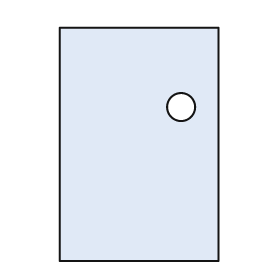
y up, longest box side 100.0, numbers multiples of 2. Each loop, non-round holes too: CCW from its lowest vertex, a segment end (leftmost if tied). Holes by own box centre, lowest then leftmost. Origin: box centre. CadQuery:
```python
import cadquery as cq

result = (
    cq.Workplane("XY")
    .moveTo(-34.0, -50.0)
    .lineTo(34.0, -50.0)
    .lineTo(34.0, 50.0)
    .lineTo(-34.0, 50.0)
    .close()
    .moveTo(18.0, 16.0)
    .circle(6.0)
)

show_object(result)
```